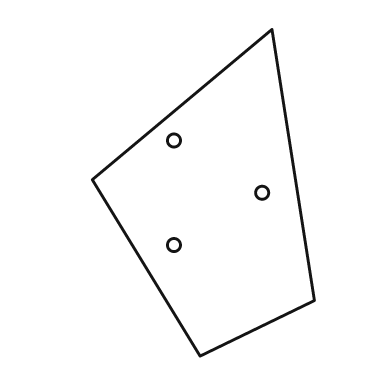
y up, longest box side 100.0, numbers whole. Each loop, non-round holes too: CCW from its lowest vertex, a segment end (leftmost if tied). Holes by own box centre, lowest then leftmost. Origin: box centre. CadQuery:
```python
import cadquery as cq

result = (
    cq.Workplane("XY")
    .moveTo(-1.0, -50.0)
    .lineTo(34.0, -33.0)
    .lineTo(21.0, 50.0)
    .lineTo(-34.0, 4.0)
    .close()
    .moveTo(-9.0, -16.0)
    .circle(2.0)
    .moveTo(18.0, 0.0)
    .circle(2.0)
    .moveTo(-9.0, 16.0)
    .circle(2.0)
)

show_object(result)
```